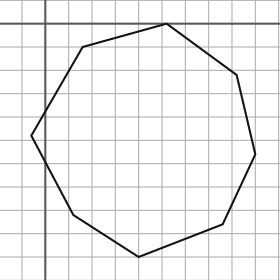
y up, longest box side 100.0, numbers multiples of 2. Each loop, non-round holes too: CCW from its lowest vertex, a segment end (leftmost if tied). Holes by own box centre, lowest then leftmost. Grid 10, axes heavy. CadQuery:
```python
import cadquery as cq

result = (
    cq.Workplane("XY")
    .moveTo(40.0, -100.0)
    .lineTo(76.0, -86.0)
    .lineTo(90.0, -56.0)
    .lineTo(82.0, -22.0)
    .lineTo(52.0, 0.0)
    .lineTo(16.0, -10.0)
    .lineTo(-6.0, -48.0)
    .lineTo(12.0, -82.0)
    .close()
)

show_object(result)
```